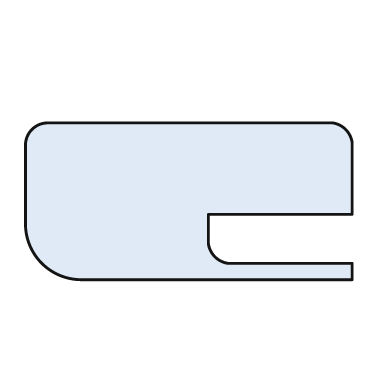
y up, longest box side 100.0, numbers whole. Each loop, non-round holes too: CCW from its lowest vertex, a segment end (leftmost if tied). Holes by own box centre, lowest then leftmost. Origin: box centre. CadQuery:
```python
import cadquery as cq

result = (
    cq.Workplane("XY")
    .moveTo(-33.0, -24.0)
    .lineTo(50.0, -24.0)
    .lineTo(50.0, -19.0)
    .lineTo(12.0, -19.0)
    .threePointArc((8.0, -17.0), (6.0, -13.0))
    .lineTo(6.0, -4.0)
    .lineTo(50.0, -4.0)
    .lineTo(50.0, 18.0)
    .threePointArc((48.0, 22.0), (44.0, 24.0))
    .lineTo(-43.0, 24.0)
    .threePointArc((-48.0, 22.0), (-50.0, 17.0))
    .lineTo(-50.0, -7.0)
    .threePointArc((-45.0, -19.0), (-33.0, -24.0))
    .close()
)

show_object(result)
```